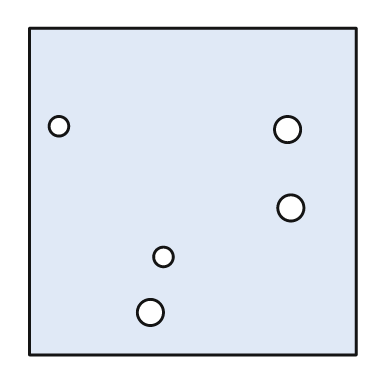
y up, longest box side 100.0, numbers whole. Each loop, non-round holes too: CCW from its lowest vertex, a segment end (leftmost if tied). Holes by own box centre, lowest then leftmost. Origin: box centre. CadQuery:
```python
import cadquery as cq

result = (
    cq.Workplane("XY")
    .moveTo(-50.0, -50.0)
    .lineTo(50.0, -50.0)
    .lineTo(50.0, 50.0)
    .lineTo(-50.0, 50.0)
    .close()
    .moveTo(-13.0, -37.0)
    .circle(4.0)
    .moveTo(-9.0, -20.0)
    .circle(3.0)
    .moveTo(30.0, -5.0)
    .circle(4.0)
    .moveTo(29.0, 19.0)
    .circle(4.0)
    .moveTo(-41.0, 20.0)
    .circle(3.0)
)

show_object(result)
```